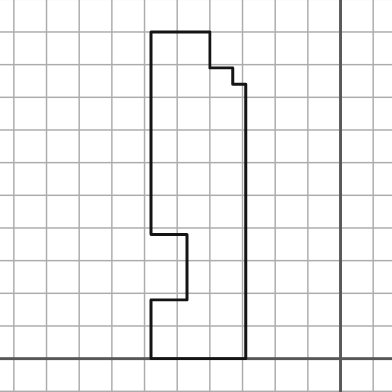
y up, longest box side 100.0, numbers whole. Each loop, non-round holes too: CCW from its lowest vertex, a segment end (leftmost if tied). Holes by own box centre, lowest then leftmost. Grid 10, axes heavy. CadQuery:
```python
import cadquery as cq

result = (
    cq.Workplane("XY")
    .moveTo(-58.0, 0.0)
    .lineTo(-29.0, 0.0)
    .lineTo(-29.0, 84.0)
    .lineTo(-33.0, 84.0)
    .lineTo(-33.0, 89.0)
    .lineTo(-40.0, 89.0)
    .lineTo(-40.0, 100.0)
    .lineTo(-58.0, 100.0)
    .lineTo(-58.0, 38.0)
    .lineTo(-47.0, 38.0)
    .lineTo(-47.0, 18.0)
    .lineTo(-58.0, 18.0)
    .close()
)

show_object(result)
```